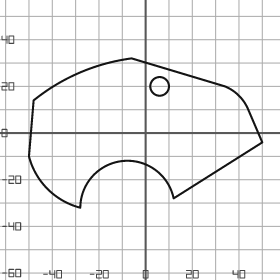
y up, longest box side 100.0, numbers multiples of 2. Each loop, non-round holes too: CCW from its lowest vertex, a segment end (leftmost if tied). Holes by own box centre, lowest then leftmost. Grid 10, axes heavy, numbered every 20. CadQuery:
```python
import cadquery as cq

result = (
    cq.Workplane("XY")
    .moveTo(-28.0, -32.0)
    .threePointArc((-10.0, -12.0), (12.0, -28.0))
    .lineTo(50.0, -4.0)
    .lineTo(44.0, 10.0)
    .threePointArc((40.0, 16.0), (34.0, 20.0))
    .lineTo(-6.0, 32.0)
    .threePointArc((-28.0, 26.0), (-48.0, 14.0))
    .lineTo(-50.0, -10.0)
    .threePointArc((-42.0, -24.0), (-28.0, -32.0))
    .close()
    .moveTo(6.0, 20.0)
    .circle(4.0)
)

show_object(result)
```